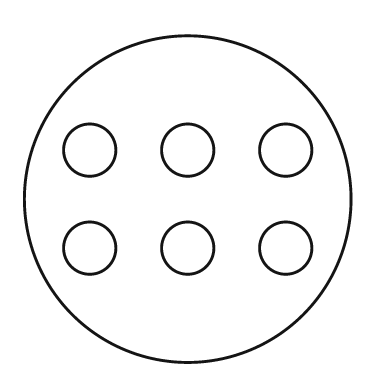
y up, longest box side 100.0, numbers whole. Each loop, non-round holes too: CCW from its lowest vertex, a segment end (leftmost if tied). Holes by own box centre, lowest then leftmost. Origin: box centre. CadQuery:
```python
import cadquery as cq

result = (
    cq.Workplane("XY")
    .moveTo(0.0, 0.0)
    .circle(50.0)
    .moveTo(-30.0, -15.0)
    .circle(8.0)
    .moveTo(0.0, -15.0)
    .circle(8.0)
    .moveTo(30.0, -15.0)
    .circle(8.0)
    .moveTo(-30.0, 15.0)
    .circle(8.0)
    .moveTo(0.0, 15.0)
    .circle(8.0)
    .moveTo(30.0, 15.0)
    .circle(8.0)
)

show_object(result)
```